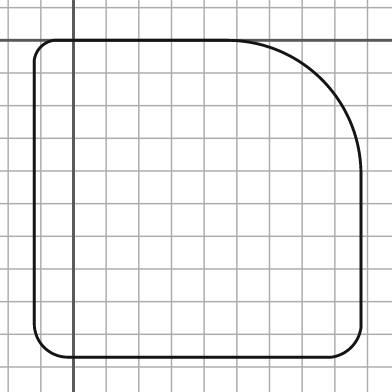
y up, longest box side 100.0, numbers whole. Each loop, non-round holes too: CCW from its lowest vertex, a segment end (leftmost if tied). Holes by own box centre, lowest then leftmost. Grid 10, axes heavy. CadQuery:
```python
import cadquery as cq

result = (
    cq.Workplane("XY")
    .moveTo(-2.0, -97.0)
    .lineTo(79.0, -97.0)
    .threePointArc((85.0, -94.0), (88.0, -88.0))
    .lineTo(88.0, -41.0)
    .threePointArc((76.0, -12.0), (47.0, 0.0))
    .lineTo(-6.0, 0.0)
    .threePointArc((-10.0, -2.0), (-12.0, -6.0))
    .lineTo(-12.0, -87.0)
    .threePointArc((-9.0, -94.0), (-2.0, -97.0))
    .close()
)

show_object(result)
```